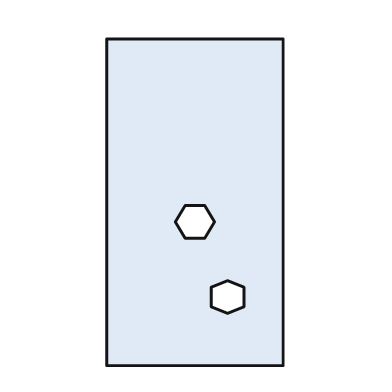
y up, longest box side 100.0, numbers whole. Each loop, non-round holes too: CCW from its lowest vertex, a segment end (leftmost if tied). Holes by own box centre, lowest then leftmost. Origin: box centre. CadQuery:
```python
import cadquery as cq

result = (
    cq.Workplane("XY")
    .moveTo(-27.0, -50.0)
    .lineTo(27.0, -50.0)
    .lineTo(27.0, 50.0)
    .lineTo(-27.0, 50.0)
    .close()
    .moveTo(10.0, -34.0)
    .lineTo(15.0, -32.0)
    .lineTo(15.0, -26.0)
    .lineTo(10.0, -24.0)
    .lineTo(5.0, -26.0)
    .lineTo(5.0, -32.0)
    .close()
    .moveTo(-3.0, -11.0)
    .lineTo(3.0, -11.0)
    .lineTo(6.0, -6.0)
    .lineTo(3.0, -1.0)
    .lineTo(-3.0, -1.0)
    .lineTo(-6.0, -6.0)
    .close()
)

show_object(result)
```